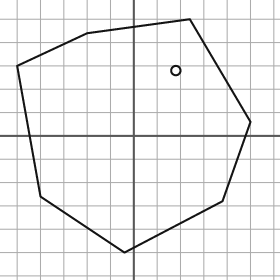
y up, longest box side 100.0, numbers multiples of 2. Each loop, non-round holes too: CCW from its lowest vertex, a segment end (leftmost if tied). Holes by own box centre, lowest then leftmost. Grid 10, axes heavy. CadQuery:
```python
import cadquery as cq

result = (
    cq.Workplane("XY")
    .moveTo(-4.0, -50.0)
    .lineTo(38.0, -28.0)
    .lineTo(50.0, 6.0)
    .lineTo(24.0, 50.0)
    .lineTo(-20.0, 44.0)
    .lineTo(-50.0, 30.0)
    .lineTo(-40.0, -26.0)
    .close()
    .moveTo(18.0, 28.0)
    .circle(2.0)
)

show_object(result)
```